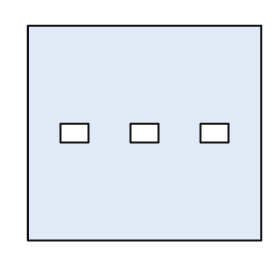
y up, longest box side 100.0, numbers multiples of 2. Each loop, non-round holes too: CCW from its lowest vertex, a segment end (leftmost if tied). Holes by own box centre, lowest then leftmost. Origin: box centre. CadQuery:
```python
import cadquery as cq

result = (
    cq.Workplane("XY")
    .moveTo(-50.0, -46.0)
    .lineTo(50.0, -46.0)
    .lineTo(50.0, 46.0)
    .lineTo(-50.0, 46.0)
    .close()
    .moveTo(-36.0, -4.0)
    .lineTo(-24.0, -4.0)
    .lineTo(-24.0, 4.0)
    .lineTo(-36.0, 4.0)
    .close()
    .moveTo(-6.0, -4.0)
    .lineTo(6.0, -4.0)
    .lineTo(6.0, 4.0)
    .lineTo(-6.0, 4.0)
    .close()
    .moveTo(24.0, -4.0)
    .lineTo(36.0, -4.0)
    .lineTo(36.0, 4.0)
    .lineTo(24.0, 4.0)
    .close()
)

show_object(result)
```